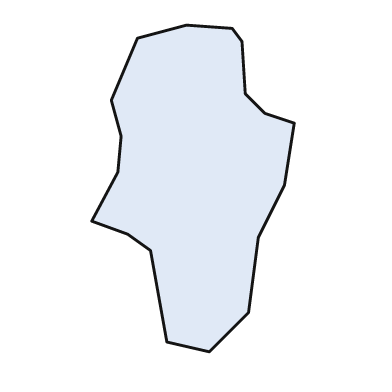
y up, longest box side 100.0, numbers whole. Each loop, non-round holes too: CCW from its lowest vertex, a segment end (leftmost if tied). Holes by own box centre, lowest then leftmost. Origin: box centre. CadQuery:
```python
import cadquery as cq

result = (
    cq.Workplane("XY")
    .moveTo(5.0, -50.0)
    .lineTo(17.0, -38.0)
    .lineTo(20.0, -15.0)
    .lineTo(28.0, 1.0)
    .lineTo(31.0, 20.0)
    .lineTo(22.0, 23.0)
    .lineTo(16.0, 29.0)
    .lineTo(15.0, 45.0)
    .lineTo(12.0, 49.0)
    .lineTo(-2.0, 50.0)
    .lineTo(-17.0, 46.0)
    .lineTo(-25.0, 27.0)
    .lineTo(-22.0, 16.0)
    .lineTo(-23.0, 5.0)
    .lineTo(-31.0, -10.0)
    .lineTo(-20.0, -14.0)
    .lineTo(-13.0, -19.0)
    .lineTo(-8.0, -47.0)
    .close()
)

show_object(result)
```